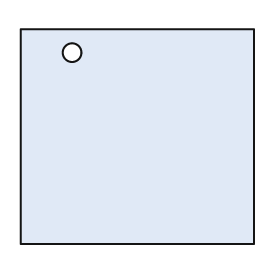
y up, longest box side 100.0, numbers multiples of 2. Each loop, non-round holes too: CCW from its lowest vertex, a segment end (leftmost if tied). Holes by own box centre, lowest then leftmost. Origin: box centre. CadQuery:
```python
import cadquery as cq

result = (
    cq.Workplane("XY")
    .moveTo(-50.0, -46.0)
    .lineTo(50.0, -46.0)
    .lineTo(50.0, 46.0)
    .lineTo(-50.0, 46.0)
    .close()
    .moveTo(-28.0, 36.0)
    .circle(4.0)
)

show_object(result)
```